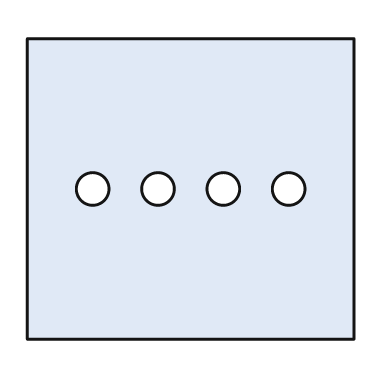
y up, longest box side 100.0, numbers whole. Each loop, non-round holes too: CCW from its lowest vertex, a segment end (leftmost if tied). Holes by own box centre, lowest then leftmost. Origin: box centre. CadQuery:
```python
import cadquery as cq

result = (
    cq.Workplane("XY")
    .moveTo(-50.0, -46.0)
    .lineTo(50.0, -46.0)
    .lineTo(50.0, 46.0)
    .lineTo(-50.0, 46.0)
    .close()
    .moveTo(-30.0, 0.0)
    .circle(5.0)
    .moveTo(-10.0, 0.0)
    .circle(5.0)
    .moveTo(10.0, 0.0)
    .circle(5.0)
    .moveTo(30.0, 0.0)
    .circle(5.0)
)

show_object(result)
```